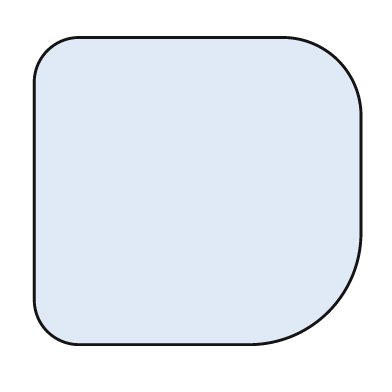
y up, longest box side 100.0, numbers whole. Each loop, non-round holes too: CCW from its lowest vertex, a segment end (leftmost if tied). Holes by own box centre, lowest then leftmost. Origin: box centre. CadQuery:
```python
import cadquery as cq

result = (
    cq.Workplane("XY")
    .moveTo(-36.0, -47.0)
    .lineTo(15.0, -47.0)
    .threePointArc((40.0, -37.0), (50.0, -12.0))
    .lineTo(50.0, 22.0)
    .threePointArc((43.0, 40.0), (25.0, 47.0))
    .lineTo(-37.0, 47.0)
    .threePointArc((-46.0, 43.0), (-50.0, 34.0))
    .lineTo(-50.0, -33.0)
    .threePointArc((-46.0, -43.0), (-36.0, -47.0))
    .close()
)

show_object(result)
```